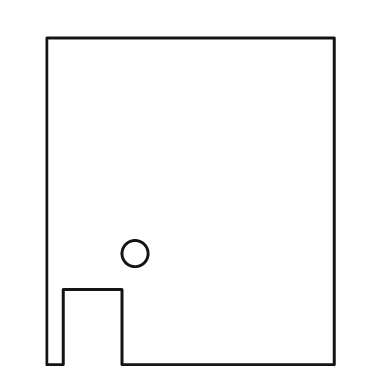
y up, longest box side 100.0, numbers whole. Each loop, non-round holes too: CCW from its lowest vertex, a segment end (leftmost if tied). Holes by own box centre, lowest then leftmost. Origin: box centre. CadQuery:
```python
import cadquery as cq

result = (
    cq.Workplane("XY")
    .moveTo(-44.0, -50.0)
    .lineTo(-39.0, -50.0)
    .lineTo(-39.0, -27.0)
    .lineTo(-21.0, -27.0)
    .lineTo(-21.0, -50.0)
    .lineTo(44.0, -50.0)
    .lineTo(44.0, 50.0)
    .lineTo(-44.0, 50.0)
    .close()
    .moveTo(-17.0, -16.0)
    .circle(4.0)
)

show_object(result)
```